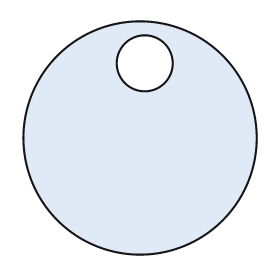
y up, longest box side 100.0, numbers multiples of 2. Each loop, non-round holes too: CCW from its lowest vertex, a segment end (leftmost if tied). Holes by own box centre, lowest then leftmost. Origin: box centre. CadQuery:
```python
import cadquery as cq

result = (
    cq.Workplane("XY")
    .moveTo(0.0, 0.0)
    .circle(50.0)
    .moveTo(2.0, 32.0)
    .circle(12.0)
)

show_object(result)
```